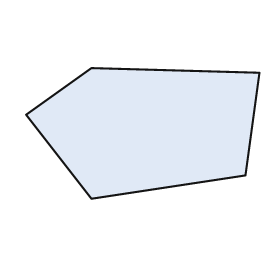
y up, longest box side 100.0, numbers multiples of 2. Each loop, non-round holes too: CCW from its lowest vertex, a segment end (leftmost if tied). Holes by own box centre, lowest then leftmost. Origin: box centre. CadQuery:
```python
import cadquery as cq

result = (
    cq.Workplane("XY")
    .moveTo(-22.0, -28.0)
    .lineTo(44.0, -18.0)
    .lineTo(50.0, 26.0)
    .lineTo(-22.0, 28.0)
    .lineTo(-50.0, 8.0)
    .close()
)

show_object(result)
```